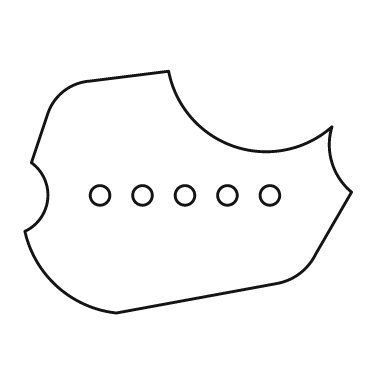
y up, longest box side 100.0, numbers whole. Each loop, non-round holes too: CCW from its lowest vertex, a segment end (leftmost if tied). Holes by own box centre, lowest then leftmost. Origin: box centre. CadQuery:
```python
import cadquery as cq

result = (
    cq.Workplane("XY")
    .moveTo(-22.0, -37.0)
    .lineTo(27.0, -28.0)
    .threePointArc((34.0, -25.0), (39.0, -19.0))
    .lineTo(50.0, 0.0)
    .threePointArc((44.0, 9.0), (44.0, 20.0))
    .threePointArc((14.0, 14.0), (-6.0, 37.0))
    .lineTo(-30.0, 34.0)
    .threePointArc((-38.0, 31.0), (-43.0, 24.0))
    .lineTo(-48.0, 9.0)
    .threePointArc((-43.0, -2.0), (-50.0, -12.0))
    .threePointArc((-40.0, -29.0), (-22.0, -37.0))
    .close()
    .moveTo(-27.0, -1.0)
    .circle(3.0)
    .moveTo(-14.0, -1.0)
    .circle(3.0)
    .moveTo(-1.0, -1.0)
    .circle(3.0)
    .moveTo(12.0, -1.0)
    .circle(3.0)
    .moveTo(25.0, -1.0)
    .circle(3.0)
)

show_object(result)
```